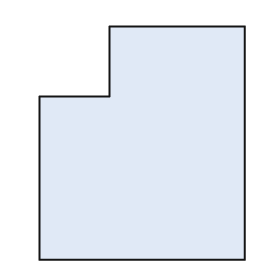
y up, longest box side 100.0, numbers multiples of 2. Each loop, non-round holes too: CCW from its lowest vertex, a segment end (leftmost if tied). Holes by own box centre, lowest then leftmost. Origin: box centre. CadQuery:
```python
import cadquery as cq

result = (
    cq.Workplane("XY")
    .moveTo(-44.0, -50.0)
    .lineTo(44.0, -50.0)
    .lineTo(44.0, 50.0)
    .lineTo(-14.0, 50.0)
    .lineTo(-14.0, 20.0)
    .lineTo(-44.0, 20.0)
    .close()
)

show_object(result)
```